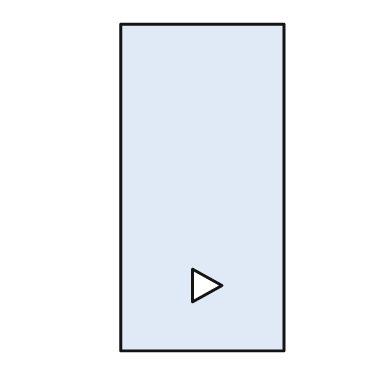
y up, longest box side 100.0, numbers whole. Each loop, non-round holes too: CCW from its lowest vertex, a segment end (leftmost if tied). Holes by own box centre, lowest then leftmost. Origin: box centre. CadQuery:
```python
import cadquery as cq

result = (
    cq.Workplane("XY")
    .moveTo(-25.0, -50.0)
    .lineTo(25.0, -50.0)
    .lineTo(25.0, 50.0)
    .lineTo(-25.0, 50.0)
    .close()
    .moveTo(-3.0, -35.0)
    .lineTo(6.0, -30.0)
    .lineTo(-3.0, -25.0)
    .close()
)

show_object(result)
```